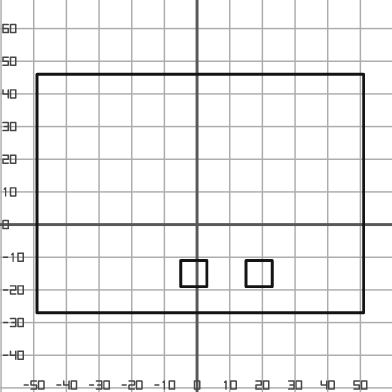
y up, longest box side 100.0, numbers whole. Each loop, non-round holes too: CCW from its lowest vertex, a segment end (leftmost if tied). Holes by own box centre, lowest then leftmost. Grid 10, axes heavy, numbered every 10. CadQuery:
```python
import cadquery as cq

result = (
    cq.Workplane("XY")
    .moveTo(-49.0, -27.0)
    .lineTo(51.0, -27.0)
    .lineTo(51.0, 46.0)
    .lineTo(-49.0, 46.0)
    .close()
    .moveTo(-5.0, -19.0)
    .lineTo(3.0, -19.0)
    .lineTo(3.0, -11.0)
    .lineTo(-5.0, -11.0)
    .close()
    .moveTo(15.0, -19.0)
    .lineTo(23.0, -19.0)
    .lineTo(23.0, -11.0)
    .lineTo(15.0, -11.0)
    .close()
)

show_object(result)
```